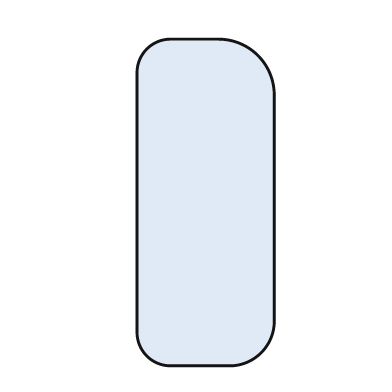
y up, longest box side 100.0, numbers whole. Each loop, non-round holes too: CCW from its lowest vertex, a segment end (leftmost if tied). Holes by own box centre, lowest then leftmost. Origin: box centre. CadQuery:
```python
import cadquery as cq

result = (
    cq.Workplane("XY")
    .moveTo(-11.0, -50.0)
    .lineTo(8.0, -50.0)
    .threePointArc((17.0, -46.0), (21.0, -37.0))
    .lineTo(21.0, 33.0)
    .threePointArc((16.0, 45.0), (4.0, 50.0))
    .lineTo(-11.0, 50.0)
    .threePointArc((-18.0, 47.0), (-21.0, 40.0))
    .lineTo(-21.0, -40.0)
    .threePointArc((-18.0, -47.0), (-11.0, -50.0))
    .close()
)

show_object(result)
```